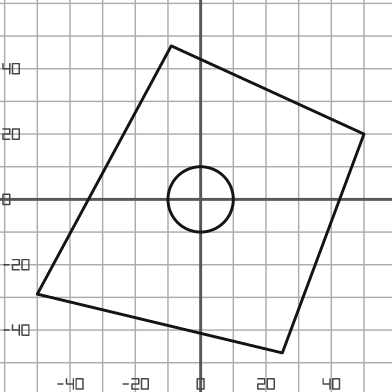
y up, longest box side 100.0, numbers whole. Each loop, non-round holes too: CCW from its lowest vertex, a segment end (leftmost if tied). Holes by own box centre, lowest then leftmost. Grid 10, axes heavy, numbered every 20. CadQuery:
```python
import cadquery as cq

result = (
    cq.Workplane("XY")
    .moveTo(25.0, -47.0)
    .lineTo(50.0, 20.0)
    .lineTo(-9.0, 47.0)
    .lineTo(-50.0, -29.0)
    .close()
    .moveTo(0.0, 0.0)
    .circle(10.0)
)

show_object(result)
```